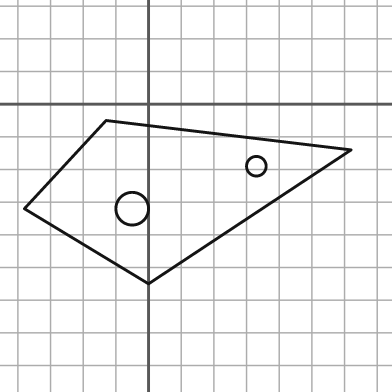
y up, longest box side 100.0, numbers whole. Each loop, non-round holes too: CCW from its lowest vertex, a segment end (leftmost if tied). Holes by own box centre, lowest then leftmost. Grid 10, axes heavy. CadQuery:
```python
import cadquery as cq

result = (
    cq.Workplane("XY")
    .moveTo(0.0, -55.0)
    .lineTo(62.0, -14.0)
    .lineTo(-13.0, -5.0)
    .lineTo(-38.0, -32.0)
    .close()
    .moveTo(-5.0, -32.0)
    .circle(5.0)
    .moveTo(33.0, -19.0)
    .circle(3.0)
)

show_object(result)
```